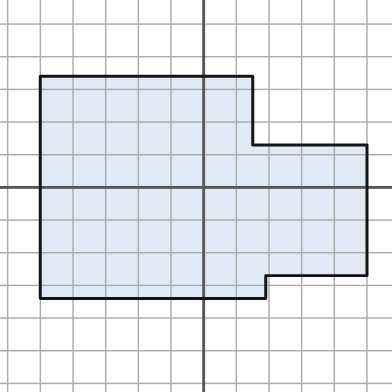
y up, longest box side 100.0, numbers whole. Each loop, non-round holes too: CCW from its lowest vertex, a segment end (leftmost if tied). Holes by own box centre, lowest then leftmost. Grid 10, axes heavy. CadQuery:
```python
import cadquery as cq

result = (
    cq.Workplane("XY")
    .moveTo(-50.0, -34.0)
    .lineTo(19.0, -34.0)
    .lineTo(19.0, -27.0)
    .lineTo(50.0, -27.0)
    .lineTo(50.0, 13.0)
    .lineTo(15.0, 13.0)
    .lineTo(15.0, 34.0)
    .lineTo(-50.0, 34.0)
    .close()
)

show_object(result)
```